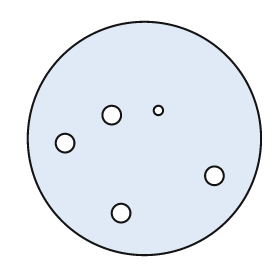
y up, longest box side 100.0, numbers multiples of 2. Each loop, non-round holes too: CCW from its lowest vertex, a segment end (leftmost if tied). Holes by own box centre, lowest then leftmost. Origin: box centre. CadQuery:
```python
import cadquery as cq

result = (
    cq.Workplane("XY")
    .moveTo(0.0, 0.0)
    .circle(50.0)
    .moveTo(-10.0, -32.0)
    .circle(4.0)
    .moveTo(30.0, -16.0)
    .circle(4.0)
    .moveTo(-34.0, -2.0)
    .circle(4.0)
    .moveTo(-14.0, 10.0)
    .circle(4.0)
    .moveTo(6.0, 12.0)
    .circle(2.0)
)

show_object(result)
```